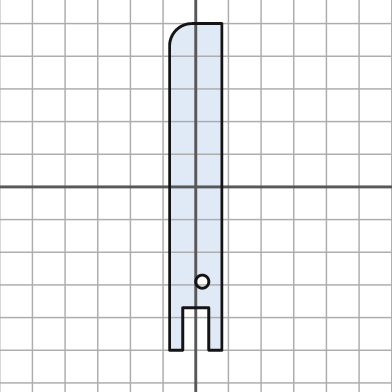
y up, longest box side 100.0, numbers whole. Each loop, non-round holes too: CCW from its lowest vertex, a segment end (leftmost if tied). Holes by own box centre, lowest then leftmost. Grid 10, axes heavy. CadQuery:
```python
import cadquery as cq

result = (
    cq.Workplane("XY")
    .moveTo(-8.0, -50.0)
    .lineTo(-4.0, -50.0)
    .lineTo(-4.0, -37.0)
    .lineTo(4.0, -37.0)
    .lineTo(4.0, -50.0)
    .lineTo(8.0, -50.0)
    .lineTo(8.0, 50.0)
    .lineTo(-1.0, 50.0)
    .threePointArc((-6.0, 48.0), (-8.0, 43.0))
    .close()
    .moveTo(2.0, -29.0)
    .circle(2.0)
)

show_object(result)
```